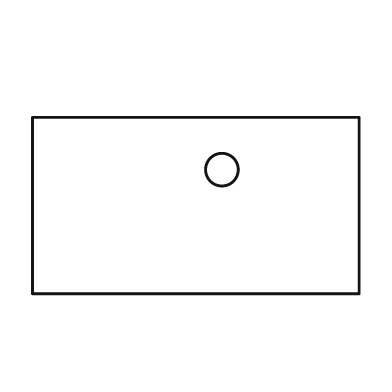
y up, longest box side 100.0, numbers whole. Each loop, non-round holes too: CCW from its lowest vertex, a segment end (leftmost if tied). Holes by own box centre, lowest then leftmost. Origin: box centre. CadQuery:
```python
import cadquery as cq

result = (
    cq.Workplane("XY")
    .moveTo(-50.0, -27.0)
    .lineTo(50.0, -27.0)
    .lineTo(50.0, 27.0)
    .lineTo(-50.0, 27.0)
    .close()
    .moveTo(8.0, 11.0)
    .circle(5.0)
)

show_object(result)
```